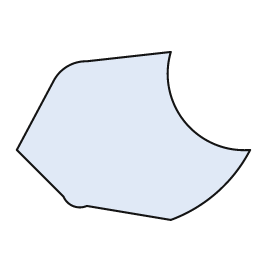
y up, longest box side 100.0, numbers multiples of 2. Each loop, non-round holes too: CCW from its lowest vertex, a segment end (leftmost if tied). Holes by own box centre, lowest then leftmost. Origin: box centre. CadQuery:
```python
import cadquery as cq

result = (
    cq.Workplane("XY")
    .moveTo(16.0, -36.0)
    .threePointArc((36.0, -24.0), (50.0, -6.0))
    .threePointArc((22.0, 6.0), (16.0, 36.0))
    .lineTo(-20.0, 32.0)
    .threePointArc((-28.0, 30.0), (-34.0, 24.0))
    .lineTo(-50.0, -6.0)
    .lineTo(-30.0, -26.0)
    .threePointArc((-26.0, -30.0), (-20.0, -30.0))
    .close()
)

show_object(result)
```